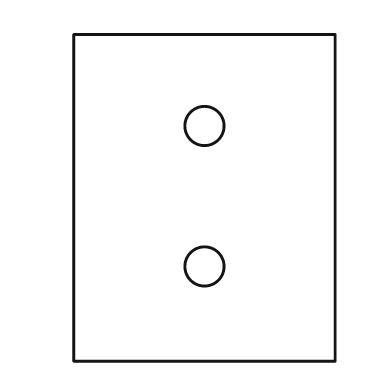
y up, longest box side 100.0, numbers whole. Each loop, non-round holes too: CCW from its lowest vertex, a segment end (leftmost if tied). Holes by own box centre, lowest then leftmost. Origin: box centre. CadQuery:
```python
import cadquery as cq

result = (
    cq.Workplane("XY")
    .moveTo(-40.0, -50.0)
    .lineTo(40.0, -50.0)
    .lineTo(40.0, 50.0)
    .lineTo(-40.0, 50.0)
    .close()
    .moveTo(0.0, -21.0)
    .circle(6.0)
    .moveTo(0.0, 22.0)
    .circle(6.0)
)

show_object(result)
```